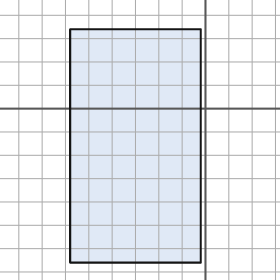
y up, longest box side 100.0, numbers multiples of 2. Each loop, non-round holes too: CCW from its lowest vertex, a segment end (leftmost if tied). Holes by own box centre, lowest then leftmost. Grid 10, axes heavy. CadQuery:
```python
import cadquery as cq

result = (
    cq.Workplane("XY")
    .moveTo(-58.0, -66.0)
    .lineTo(-2.0, -66.0)
    .lineTo(-2.0, 34.0)
    .lineTo(-58.0, 34.0)
    .close()
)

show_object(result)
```